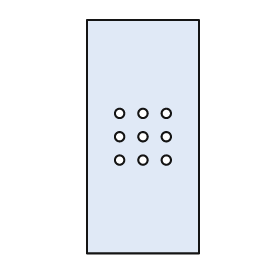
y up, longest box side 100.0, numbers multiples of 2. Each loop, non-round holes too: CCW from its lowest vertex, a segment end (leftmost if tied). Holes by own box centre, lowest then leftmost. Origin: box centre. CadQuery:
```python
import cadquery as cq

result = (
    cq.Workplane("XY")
    .moveTo(-24.0, -50.0)
    .lineTo(24.0, -50.0)
    .lineTo(24.0, 50.0)
    .lineTo(-24.0, 50.0)
    .close()
    .moveTo(-10.0, -10.0)
    .circle(2.0)
    .moveTo(0.0, -10.0)
    .circle(2.0)
    .moveTo(10.0, -10.0)
    .circle(2.0)
    .moveTo(-10.0, 0.0)
    .circle(2.0)
    .moveTo(0.0, 0.0)
    .circle(2.0)
    .moveTo(10.0, 0.0)
    .circle(2.0)
    .moveTo(-10.0, 10.0)
    .circle(2.0)
    .moveTo(0.0, 10.0)
    .circle(2.0)
    .moveTo(10.0, 10.0)
    .circle(2.0)
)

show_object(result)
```